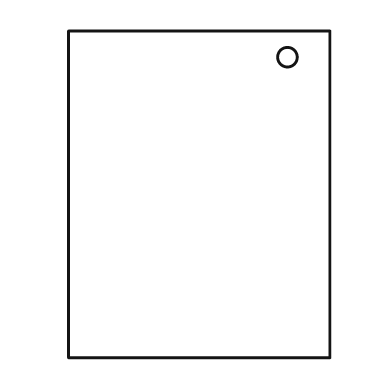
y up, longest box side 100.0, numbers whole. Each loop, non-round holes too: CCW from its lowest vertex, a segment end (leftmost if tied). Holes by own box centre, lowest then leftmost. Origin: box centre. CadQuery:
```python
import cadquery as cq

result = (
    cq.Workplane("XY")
    .moveTo(-40.0, -50.0)
    .lineTo(40.0, -50.0)
    .lineTo(40.0, 50.0)
    .lineTo(-40.0, 50.0)
    .close()
    .moveTo(27.0, 42.0)
    .circle(3.0)
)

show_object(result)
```